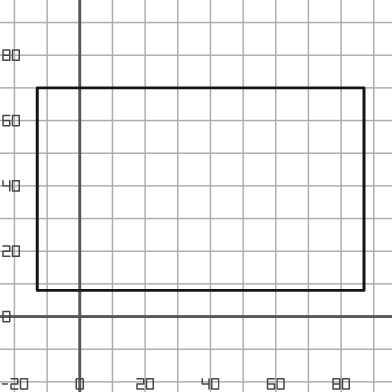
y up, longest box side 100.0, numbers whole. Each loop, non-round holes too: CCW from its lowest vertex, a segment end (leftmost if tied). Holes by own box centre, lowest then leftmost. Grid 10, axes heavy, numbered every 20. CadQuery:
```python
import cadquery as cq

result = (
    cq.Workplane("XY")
    .moveTo(-13.0, 8.0)
    .lineTo(87.0, 8.0)
    .lineTo(87.0, 70.0)
    .lineTo(-13.0, 70.0)
    .close()
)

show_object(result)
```